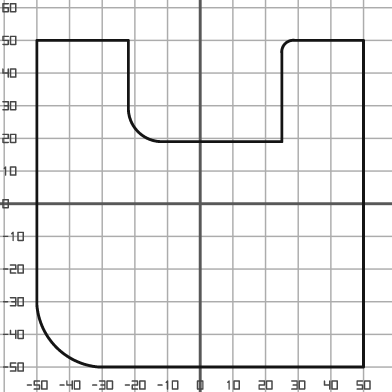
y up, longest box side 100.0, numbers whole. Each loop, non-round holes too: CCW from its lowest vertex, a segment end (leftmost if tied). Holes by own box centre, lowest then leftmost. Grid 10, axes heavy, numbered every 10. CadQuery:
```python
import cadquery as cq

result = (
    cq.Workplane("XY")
    .moveTo(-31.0, -50.0)
    .lineTo(50.0, -50.0)
    .lineTo(50.0, 50.0)
    .lineTo(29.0, 50.0)
    .threePointArc((26.0, 49.0), (25.0, 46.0))
    .lineTo(25.0, 19.0)
    .lineTo(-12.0, 19.0)
    .threePointArc((-19.0, 22.0), (-22.0, 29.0))
    .lineTo(-22.0, 50.0)
    .lineTo(-50.0, 50.0)
    .lineTo(-50.0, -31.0)
    .threePointArc((-44.0, -44.0), (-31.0, -50.0))
    .close()
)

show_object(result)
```